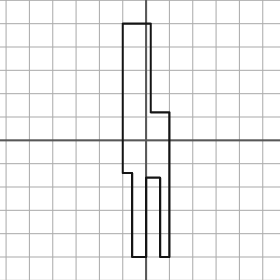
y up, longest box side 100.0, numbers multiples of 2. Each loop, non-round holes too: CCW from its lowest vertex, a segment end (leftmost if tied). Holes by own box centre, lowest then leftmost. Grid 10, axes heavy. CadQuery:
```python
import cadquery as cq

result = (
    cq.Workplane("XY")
    .moveTo(-6.0, -50.0)
    .lineTo(0.0, -50.0)
    .lineTo(0.0, -16.0)
    .lineTo(6.0, -16.0)
    .lineTo(6.0, -50.0)
    .lineTo(10.0, -50.0)
    .lineTo(10.0, 12.0)
    .lineTo(2.0, 12.0)
    .lineTo(2.0, 50.0)
    .lineTo(-10.0, 50.0)
    .lineTo(-10.0, -14.0)
    .lineTo(-6.0, -14.0)
    .close()
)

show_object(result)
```